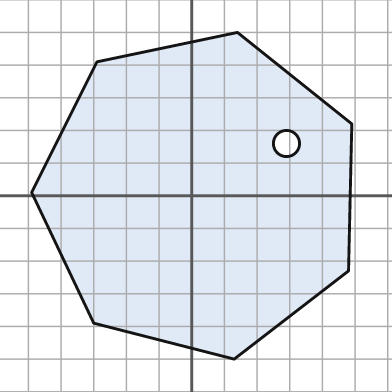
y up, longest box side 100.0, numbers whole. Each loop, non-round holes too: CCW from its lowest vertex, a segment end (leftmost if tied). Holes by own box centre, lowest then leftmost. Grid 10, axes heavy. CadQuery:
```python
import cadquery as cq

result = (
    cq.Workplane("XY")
    .moveTo(13.0, -50.0)
    .lineTo(48.0, -23.0)
    .lineTo(49.0, 22.0)
    .lineTo(14.0, 50.0)
    .lineTo(-29.0, 41.0)
    .lineTo(-49.0, 1.0)
    .lineTo(-30.0, -39.0)
    .close()
    .moveTo(29.0, 16.0)
    .circle(4.0)
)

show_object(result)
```